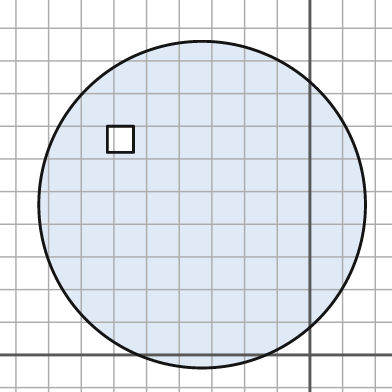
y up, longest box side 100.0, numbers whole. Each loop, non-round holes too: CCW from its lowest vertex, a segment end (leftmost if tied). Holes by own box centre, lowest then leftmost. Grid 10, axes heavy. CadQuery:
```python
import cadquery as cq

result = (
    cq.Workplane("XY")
    .moveTo(-33.0, 46.0)
    .circle(50.0)
    .moveTo(-62.0, 62.0)
    .lineTo(-54.0, 62.0)
    .lineTo(-54.0, 70.0)
    .lineTo(-62.0, 70.0)
    .close()
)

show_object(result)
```